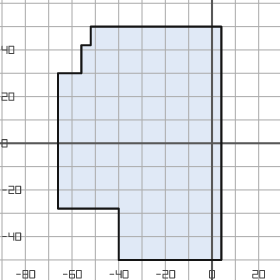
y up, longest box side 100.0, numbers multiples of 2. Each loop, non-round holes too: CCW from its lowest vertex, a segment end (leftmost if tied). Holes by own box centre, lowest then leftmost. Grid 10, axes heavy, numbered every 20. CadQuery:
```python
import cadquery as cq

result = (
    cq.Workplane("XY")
    .moveTo(-40.0, -50.0)
    .lineTo(4.0, -50.0)
    .lineTo(4.0, 50.0)
    .lineTo(-52.0, 50.0)
    .lineTo(-52.0, 42.0)
    .lineTo(-56.0, 42.0)
    .lineTo(-56.0, 30.0)
    .lineTo(-66.0, 30.0)
    .lineTo(-66.0, -28.0)
    .lineTo(-40.0, -28.0)
    .close()
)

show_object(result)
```